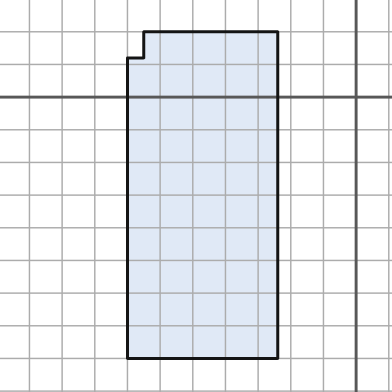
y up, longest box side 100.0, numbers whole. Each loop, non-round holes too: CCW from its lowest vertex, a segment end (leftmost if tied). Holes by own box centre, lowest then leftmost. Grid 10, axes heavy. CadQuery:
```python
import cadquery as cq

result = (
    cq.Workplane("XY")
    .moveTo(-70.0, -80.0)
    .lineTo(-24.0, -80.0)
    .lineTo(-24.0, 20.0)
    .lineTo(-65.0, 20.0)
    .lineTo(-65.0, 12.0)
    .lineTo(-70.0, 12.0)
    .close()
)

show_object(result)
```